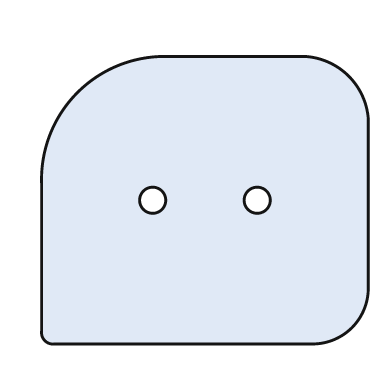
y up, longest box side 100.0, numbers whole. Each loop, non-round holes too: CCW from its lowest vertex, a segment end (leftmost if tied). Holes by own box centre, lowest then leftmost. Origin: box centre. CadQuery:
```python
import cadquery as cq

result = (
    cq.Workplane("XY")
    .moveTo(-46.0, -44.0)
    .lineTo(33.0, -44.0)
    .threePointArc((45.0, -39.0), (50.0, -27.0))
    .lineTo(50.0, 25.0)
    .threePointArc((44.0, 38.0), (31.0, 44.0))
    .lineTo(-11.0, 44.0)
    .threePointArc((-39.0, 33.0), (-50.0, 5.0))
    .lineTo(-50.0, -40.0)
    .threePointArc((-49.0, -43.0), (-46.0, -44.0))
    .close()
    .moveTo(-16.0, 0.0)
    .circle(4.0)
    .moveTo(16.0, 0.0)
    .circle(4.0)
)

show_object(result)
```